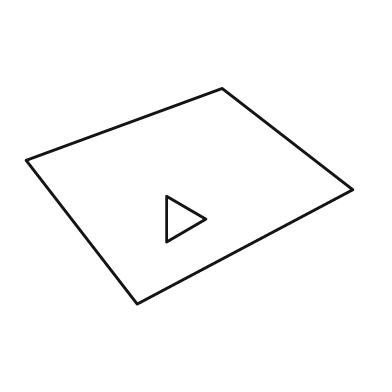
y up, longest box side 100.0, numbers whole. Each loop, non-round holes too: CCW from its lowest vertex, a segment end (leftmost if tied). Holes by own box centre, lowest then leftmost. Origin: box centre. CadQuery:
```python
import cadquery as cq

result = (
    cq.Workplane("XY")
    .moveTo(-16.0, -33.0)
    .lineTo(50.0, 2.0)
    .lineTo(10.0, 33.0)
    .lineTo(-50.0, 11.0)
    .close()
    .moveTo(-7.0, -14.0)
    .lineTo(5.0, -7.0)
    .lineTo(-7.0, 0.0)
    .close()
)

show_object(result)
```